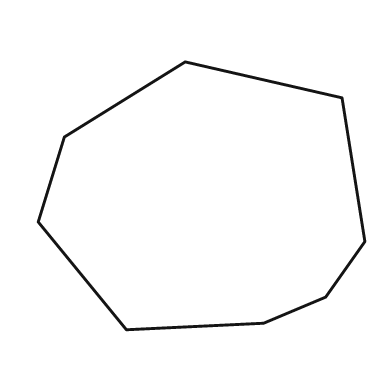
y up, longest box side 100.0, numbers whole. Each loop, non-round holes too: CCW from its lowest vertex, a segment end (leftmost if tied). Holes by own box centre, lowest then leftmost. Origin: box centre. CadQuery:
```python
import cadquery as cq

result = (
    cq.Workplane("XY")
    .moveTo(-23.0, -41.0)
    .lineTo(19.0, -39.0)
    .lineTo(38.0, -31.0)
    .lineTo(50.0, -14.0)
    .lineTo(43.0, 30.0)
    .lineTo(-5.0, 41.0)
    .lineTo(-42.0, 18.0)
    .lineTo(-50.0, -8.0)
    .close()
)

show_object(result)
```